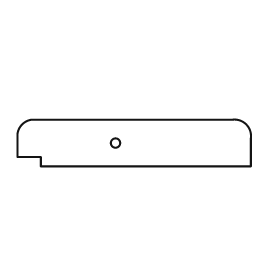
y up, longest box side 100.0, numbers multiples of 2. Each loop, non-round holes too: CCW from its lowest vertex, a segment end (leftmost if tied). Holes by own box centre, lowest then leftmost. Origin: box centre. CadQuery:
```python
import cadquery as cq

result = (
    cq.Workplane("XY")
    .moveTo(-40.0, -10.0)
    .lineTo(50.0, -10.0)
    .lineTo(50.0, 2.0)
    .threePointArc((48.0, 8.0), (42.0, 10.0))
    .lineTo(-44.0, 10.0)
    .threePointArc((-48.0, 8.0), (-50.0, 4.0))
    .lineTo(-50.0, -6.0)
    .lineTo(-40.0, -6.0)
    .close()
    .moveTo(-8.0, 0.0)
    .circle(2.0)
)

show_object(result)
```